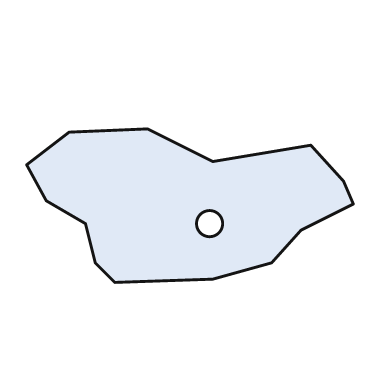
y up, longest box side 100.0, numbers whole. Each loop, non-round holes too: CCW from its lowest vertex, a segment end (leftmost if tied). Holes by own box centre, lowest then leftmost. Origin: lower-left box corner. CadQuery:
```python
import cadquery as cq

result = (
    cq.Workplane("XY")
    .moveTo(27.0, 0.0)
    .lineTo(57.0, 1.0)
    .lineTo(75.0, 6.0)
    .lineTo(84.0, 16.0)
    .lineTo(100.0, 24.0)
    .lineTo(97.0, 31.0)
    .lineTo(87.0, 42.0)
    .lineTo(57.0, 37.0)
    .lineTo(37.0, 47.0)
    .lineTo(13.0, 46.0)
    .lineTo(0.0, 36.0)
    .lineTo(6.0, 25.0)
    .lineTo(18.0, 18.0)
    .lineTo(21.0, 6.0)
    .close()
    .moveTo(56.0, 18.0)
    .circle(4.0)
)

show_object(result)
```